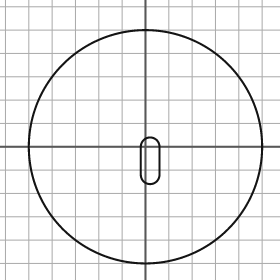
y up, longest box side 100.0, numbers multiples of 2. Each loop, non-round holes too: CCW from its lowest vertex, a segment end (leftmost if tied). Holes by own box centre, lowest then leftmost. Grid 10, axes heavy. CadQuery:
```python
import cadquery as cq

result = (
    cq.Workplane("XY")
    .moveTo(0.0, 0.0)
    .circle(50.0)
    .moveTo(-2.0, -12.0)
    .threePointArc((2.0, -16.0), (6.0, -12.0))
    .lineTo(6.0, 0.0)
    .threePointArc((2.0, 4.0), (-2.0, 0.0))
    .close()
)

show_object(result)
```